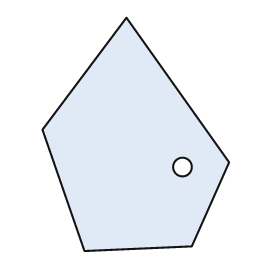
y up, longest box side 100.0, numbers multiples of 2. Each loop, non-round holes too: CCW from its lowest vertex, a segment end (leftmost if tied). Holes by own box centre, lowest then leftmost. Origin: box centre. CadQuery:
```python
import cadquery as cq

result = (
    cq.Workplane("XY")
    .moveTo(-22.0, -50.0)
    .lineTo(24.0, -48.0)
    .lineTo(40.0, -12.0)
    .lineTo(-4.0, 50.0)
    .lineTo(-40.0, 2.0)
    .close()
    .moveTo(20.0, -14.0)
    .circle(4.0)
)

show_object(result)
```